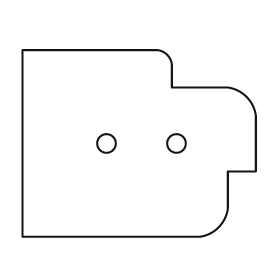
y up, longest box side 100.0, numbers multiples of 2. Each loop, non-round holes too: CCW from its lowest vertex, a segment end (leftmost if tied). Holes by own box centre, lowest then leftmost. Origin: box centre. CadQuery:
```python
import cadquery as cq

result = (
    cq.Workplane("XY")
    .moveTo(-50.0, -40.0)
    .lineTo(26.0, -40.0)
    .threePointArc((34.0, -36.0), (38.0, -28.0))
    .lineTo(38.0, -12.0)
    .lineTo(50.0, -12.0)
    .lineTo(50.0, 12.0)
    .threePointArc((46.0, 20.0), (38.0, 24.0))
    .lineTo(14.0, 24.0)
    .lineTo(14.0, 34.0)
    .threePointArc((12.0, 38.0), (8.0, 40.0))
    .lineTo(-50.0, 40.0)
    .close()
    .moveTo(-14.0, 0.0)
    .circle(4.0)
    .moveTo(16.0, 0.0)
    .circle(4.0)
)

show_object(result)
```